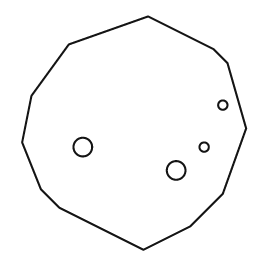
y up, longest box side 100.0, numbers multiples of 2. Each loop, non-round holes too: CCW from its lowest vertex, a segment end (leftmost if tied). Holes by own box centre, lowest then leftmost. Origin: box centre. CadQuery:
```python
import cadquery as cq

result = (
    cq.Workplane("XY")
    .moveTo(4.0, -50.0)
    .lineTo(24.0, -40.0)
    .lineTo(38.0, -26.0)
    .lineTo(48.0, 2.0)
    .lineTo(40.0, 30.0)
    .lineTo(34.0, 36.0)
    .lineTo(6.0, 50.0)
    .lineTo(-28.0, 38.0)
    .lineTo(-44.0, 16.0)
    .lineTo(-48.0, -4.0)
    .lineTo(-40.0, -24.0)
    .lineTo(-32.0, -32.0)
    .close()
    .moveTo(18.0, -16.0)
    .circle(4.0)
    .moveTo(-22.0, -6.0)
    .circle(4.0)
    .moveTo(30.0, -6.0)
    .circle(2.0)
    .moveTo(38.0, 12.0)
    .circle(2.0)
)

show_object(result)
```